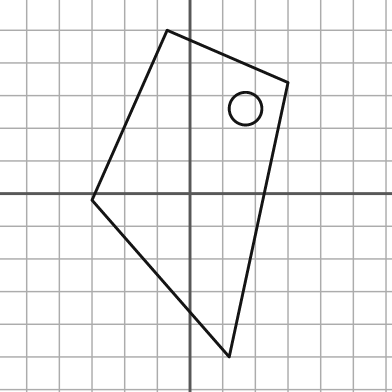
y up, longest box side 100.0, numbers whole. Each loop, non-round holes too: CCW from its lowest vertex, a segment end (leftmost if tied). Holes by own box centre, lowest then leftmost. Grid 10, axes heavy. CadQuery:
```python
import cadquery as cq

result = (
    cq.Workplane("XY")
    .moveTo(12.0, -50.0)
    .lineTo(30.0, 34.0)
    .lineTo(-7.0, 50.0)
    .lineTo(-30.0, -2.0)
    .close()
    .moveTo(17.0, 26.0)
    .circle(5.0)
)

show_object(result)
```